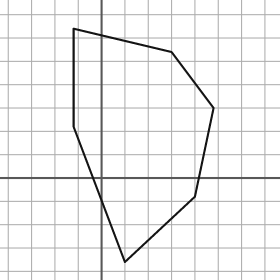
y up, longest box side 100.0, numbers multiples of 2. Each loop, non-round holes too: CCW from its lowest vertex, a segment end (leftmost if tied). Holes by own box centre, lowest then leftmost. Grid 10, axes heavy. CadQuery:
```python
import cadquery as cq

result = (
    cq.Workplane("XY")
    .moveTo(10.0, -36.0)
    .lineTo(40.0, -8.0)
    .lineTo(48.0, 30.0)
    .lineTo(30.0, 54.0)
    .lineTo(-12.0, 64.0)
    .lineTo(-12.0, 22.0)
    .close()
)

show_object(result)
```